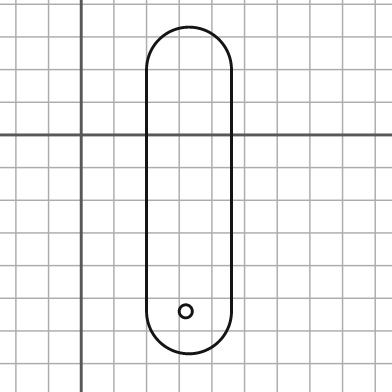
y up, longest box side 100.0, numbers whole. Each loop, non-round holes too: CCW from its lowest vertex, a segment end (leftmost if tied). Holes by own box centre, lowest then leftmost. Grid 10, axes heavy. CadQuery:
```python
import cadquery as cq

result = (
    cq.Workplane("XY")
    .moveTo(20.0, -54.0)
    .threePointArc((33.0, -67.0), (46.0, -54.0))
    .lineTo(46.0, 20.0)
    .threePointArc((33.0, 33.0), (20.0, 20.0))
    .close()
    .moveTo(32.0, -54.0)
    .circle(2.0)
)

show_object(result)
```